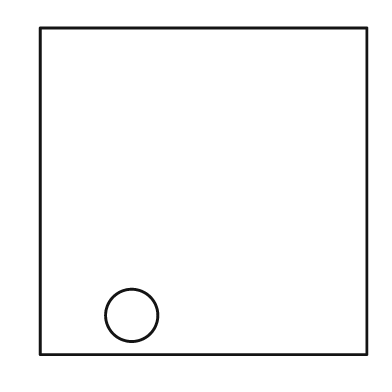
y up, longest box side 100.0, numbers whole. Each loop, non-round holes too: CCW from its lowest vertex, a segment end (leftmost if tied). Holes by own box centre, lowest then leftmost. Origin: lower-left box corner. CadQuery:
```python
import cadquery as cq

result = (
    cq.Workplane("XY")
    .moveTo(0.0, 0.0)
    .lineTo(100.0, 0.0)
    .lineTo(100.0, 100.0)
    .lineTo(0.0, 100.0)
    .close()
    .moveTo(28.0, 12.0)
    .circle(8.0)
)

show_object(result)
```